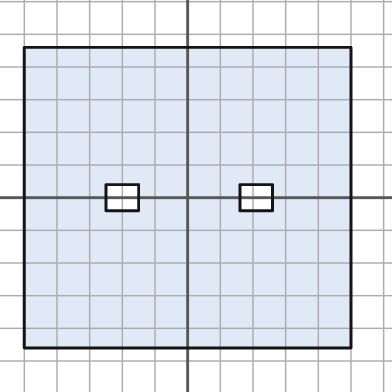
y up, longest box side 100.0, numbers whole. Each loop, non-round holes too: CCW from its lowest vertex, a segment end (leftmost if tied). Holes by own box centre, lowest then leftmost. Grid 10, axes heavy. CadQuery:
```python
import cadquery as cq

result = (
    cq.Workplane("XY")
    .moveTo(-50.0, -46.0)
    .lineTo(50.0, -46.0)
    .lineTo(50.0, 46.0)
    .lineTo(-50.0, 46.0)
    .close()
    .moveTo(-25.0, -4.0)
    .lineTo(-15.0, -4.0)
    .lineTo(-15.0, 4.0)
    .lineTo(-25.0, 4.0)
    .close()
    .moveTo(16.0, -4.0)
    .lineTo(26.0, -4.0)
    .lineTo(26.0, 4.0)
    .lineTo(16.0, 4.0)
    .close()
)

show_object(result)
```